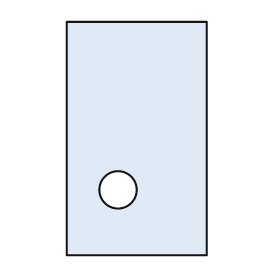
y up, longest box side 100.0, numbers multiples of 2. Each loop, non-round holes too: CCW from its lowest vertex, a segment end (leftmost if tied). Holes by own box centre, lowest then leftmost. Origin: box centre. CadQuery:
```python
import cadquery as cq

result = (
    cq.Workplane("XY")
    .moveTo(-30.0, -50.0)
    .lineTo(30.0, -50.0)
    .lineTo(30.0, 50.0)
    .lineTo(-30.0, 50.0)
    .close()
    .moveTo(-8.0, -22.0)
    .circle(8.0)
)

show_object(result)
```